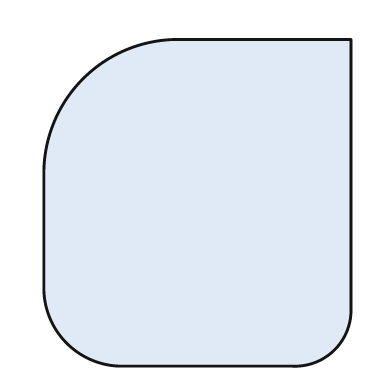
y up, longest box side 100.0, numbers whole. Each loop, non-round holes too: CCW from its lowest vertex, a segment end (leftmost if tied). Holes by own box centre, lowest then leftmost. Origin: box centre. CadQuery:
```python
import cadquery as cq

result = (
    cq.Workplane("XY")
    .moveTo(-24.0, -50.0)
    .lineTo(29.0, -50.0)
    .threePointArc((42.0, -45.0), (47.0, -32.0))
    .lineTo(47.0, 50.0)
    .lineTo(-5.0, 50.0)
    .threePointArc((-35.0, 38.0), (-47.0, 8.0))
    .lineTo(-47.0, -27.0)
    .threePointArc((-40.0, -43.0), (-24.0, -50.0))
    .close()
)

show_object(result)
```